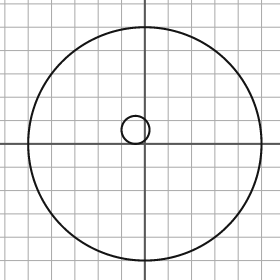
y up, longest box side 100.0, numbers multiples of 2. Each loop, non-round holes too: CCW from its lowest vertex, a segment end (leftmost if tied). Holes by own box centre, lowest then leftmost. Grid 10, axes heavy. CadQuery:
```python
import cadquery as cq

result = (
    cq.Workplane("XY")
    .moveTo(0.0, 0.0)
    .circle(50.0)
    .moveTo(-4.0, 6.0)
    .circle(6.0)
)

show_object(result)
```